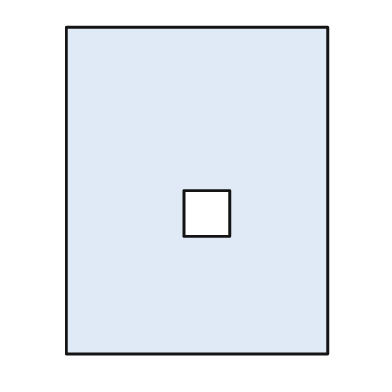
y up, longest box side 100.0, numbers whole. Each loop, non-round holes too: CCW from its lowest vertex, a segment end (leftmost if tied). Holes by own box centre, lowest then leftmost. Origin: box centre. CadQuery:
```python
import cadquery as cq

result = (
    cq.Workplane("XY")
    .moveTo(-40.0, -50.0)
    .lineTo(40.0, -50.0)
    .lineTo(40.0, 50.0)
    .lineTo(-40.0, 50.0)
    .close()
    .moveTo(-4.0, -14.0)
    .lineTo(10.0, -14.0)
    .lineTo(10.0, 0.0)
    .lineTo(-4.0, 0.0)
    .close()
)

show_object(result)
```